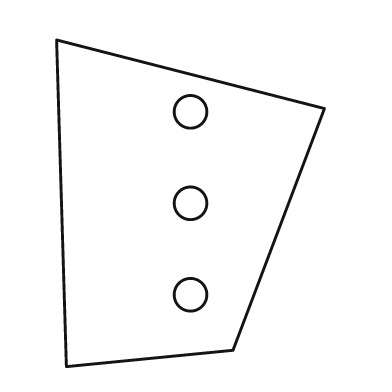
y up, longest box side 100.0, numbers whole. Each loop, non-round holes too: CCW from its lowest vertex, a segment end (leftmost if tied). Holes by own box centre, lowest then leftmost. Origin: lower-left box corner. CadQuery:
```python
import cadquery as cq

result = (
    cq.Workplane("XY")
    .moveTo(3.0, 0.0)
    .lineTo(54.0, 5.0)
    .lineTo(82.0, 79.0)
    .lineTo(0.0, 100.0)
    .close()
    .moveTo(41.0, 22.0)
    .circle(5.0)
    .moveTo(41.0, 50.0)
    .circle(5.0)
    .moveTo(41.0, 78.0)
    .circle(5.0)
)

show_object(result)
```